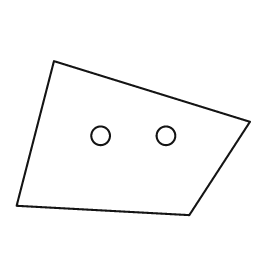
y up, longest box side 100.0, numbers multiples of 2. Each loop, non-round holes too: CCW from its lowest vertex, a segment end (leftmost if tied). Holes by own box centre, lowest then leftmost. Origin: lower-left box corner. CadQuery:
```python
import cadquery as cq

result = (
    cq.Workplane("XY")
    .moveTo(74.0, 0.0)
    .lineTo(100.0, 40.0)
    .lineTo(16.0, 66.0)
    .lineTo(0.0, 4.0)
    .close()
    .moveTo(36.0, 34.0)
    .circle(4.0)
    .moveTo(64.0, 34.0)
    .circle(4.0)
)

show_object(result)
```